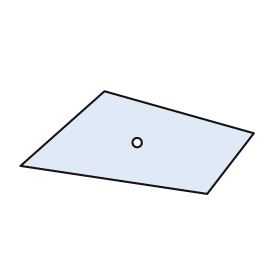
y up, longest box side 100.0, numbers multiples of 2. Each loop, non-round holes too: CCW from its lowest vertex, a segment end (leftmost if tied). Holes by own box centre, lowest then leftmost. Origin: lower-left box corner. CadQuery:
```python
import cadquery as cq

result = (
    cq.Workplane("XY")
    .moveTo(80.0, 0.0)
    .lineTo(100.0, 26.0)
    .lineTo(36.0, 44.0)
    .lineTo(0.0, 12.0)
    .close()
    .moveTo(50.0, 22.0)
    .circle(2.0)
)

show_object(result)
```